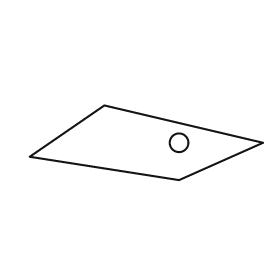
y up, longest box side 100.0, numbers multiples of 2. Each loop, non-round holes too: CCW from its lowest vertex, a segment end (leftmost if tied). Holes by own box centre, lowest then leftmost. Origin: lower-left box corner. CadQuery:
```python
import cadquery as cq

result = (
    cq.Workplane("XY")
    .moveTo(64.0, 0.0)
    .lineTo(100.0, 16.0)
    .lineTo(32.0, 32.0)
    .lineTo(0.0, 10.0)
    .close()
    .moveTo(64.0, 16.0)
    .circle(4.0)
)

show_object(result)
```